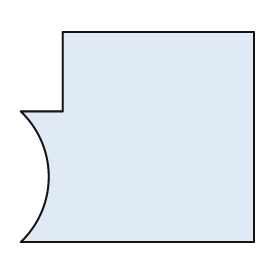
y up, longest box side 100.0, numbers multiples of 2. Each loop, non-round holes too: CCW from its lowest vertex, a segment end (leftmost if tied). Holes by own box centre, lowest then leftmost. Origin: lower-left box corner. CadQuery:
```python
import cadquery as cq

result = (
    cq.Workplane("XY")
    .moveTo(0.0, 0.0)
    .lineTo(100.0, 0.0)
    .lineTo(100.0, 90.0)
    .lineTo(18.0, 90.0)
    .lineTo(18.0, 56.0)
    .lineTo(0.0, 56.0)
    .threePointArc((12.0, 28.0), (0.0, 0.0))
    .close()
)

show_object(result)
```